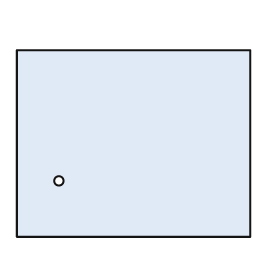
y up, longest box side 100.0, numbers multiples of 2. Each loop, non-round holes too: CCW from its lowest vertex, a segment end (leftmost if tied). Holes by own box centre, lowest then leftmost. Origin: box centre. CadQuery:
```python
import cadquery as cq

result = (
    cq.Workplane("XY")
    .moveTo(-50.0, -40.0)
    .lineTo(50.0, -40.0)
    .lineTo(50.0, 40.0)
    .lineTo(-50.0, 40.0)
    .close()
    .moveTo(-32.0, -16.0)
    .circle(2.0)
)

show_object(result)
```